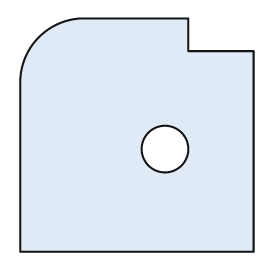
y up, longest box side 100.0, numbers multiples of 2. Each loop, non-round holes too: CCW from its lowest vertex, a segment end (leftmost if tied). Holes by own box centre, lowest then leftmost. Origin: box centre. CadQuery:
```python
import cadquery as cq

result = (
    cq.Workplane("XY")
    .moveTo(-50.0, -50.0)
    .lineTo(50.0, -50.0)
    .lineTo(50.0, 36.0)
    .lineTo(22.0, 36.0)
    .lineTo(22.0, 50.0)
    .lineTo(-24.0, 50.0)
    .threePointArc((-42.0, 42.0), (-50.0, 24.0))
    .close()
    .moveTo(12.0, -6.0)
    .circle(10.0)
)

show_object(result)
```